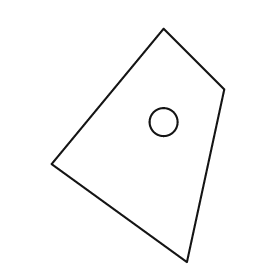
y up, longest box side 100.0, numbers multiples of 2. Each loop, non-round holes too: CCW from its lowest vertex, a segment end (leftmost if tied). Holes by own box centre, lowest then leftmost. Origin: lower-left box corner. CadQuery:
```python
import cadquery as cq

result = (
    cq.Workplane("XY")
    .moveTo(58.0, 0.0)
    .lineTo(74.0, 74.0)
    .lineTo(48.0, 100.0)
    .lineTo(0.0, 42.0)
    .close()
    .moveTo(48.0, 60.0)
    .circle(6.0)
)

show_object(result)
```